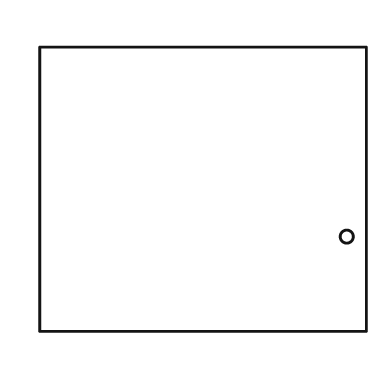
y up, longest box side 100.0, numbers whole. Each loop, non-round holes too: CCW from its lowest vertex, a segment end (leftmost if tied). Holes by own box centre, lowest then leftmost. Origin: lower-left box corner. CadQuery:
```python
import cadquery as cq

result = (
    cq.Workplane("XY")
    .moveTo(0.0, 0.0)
    .lineTo(100.0, 0.0)
    .lineTo(100.0, 87.0)
    .lineTo(0.0, 87.0)
    .close()
    .moveTo(94.0, 29.0)
    .circle(2.0)
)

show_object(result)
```